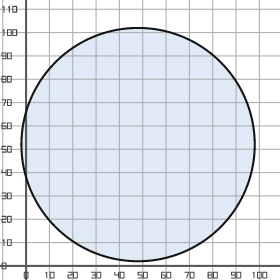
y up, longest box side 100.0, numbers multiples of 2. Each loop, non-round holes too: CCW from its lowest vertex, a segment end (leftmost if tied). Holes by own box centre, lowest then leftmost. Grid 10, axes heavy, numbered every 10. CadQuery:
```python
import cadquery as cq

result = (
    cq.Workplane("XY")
    .moveTo(48.0, 52.0)
    .circle(50.0)
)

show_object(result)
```